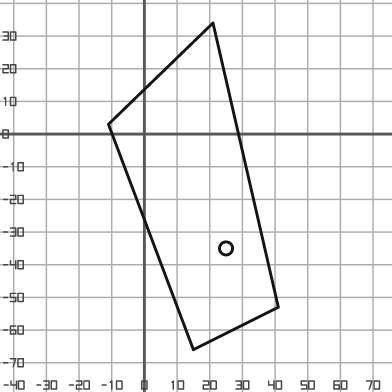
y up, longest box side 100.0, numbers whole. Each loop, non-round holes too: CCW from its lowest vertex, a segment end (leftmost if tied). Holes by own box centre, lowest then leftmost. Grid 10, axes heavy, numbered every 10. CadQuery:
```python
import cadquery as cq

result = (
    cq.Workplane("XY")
    .moveTo(15.0, -66.0)
    .lineTo(41.0, -53.0)
    .lineTo(21.0, 34.0)
    .lineTo(-11.0, 3.0)
    .close()
    .moveTo(25.0, -35.0)
    .circle(2.0)
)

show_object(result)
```